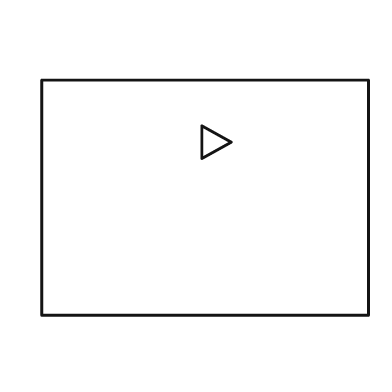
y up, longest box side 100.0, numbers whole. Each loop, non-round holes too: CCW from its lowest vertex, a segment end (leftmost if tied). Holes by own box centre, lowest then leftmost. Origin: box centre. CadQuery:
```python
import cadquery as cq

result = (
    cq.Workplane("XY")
    .moveTo(-50.0, -36.0)
    .lineTo(50.0, -36.0)
    .lineTo(50.0, 36.0)
    .lineTo(-50.0, 36.0)
    .close()
    .moveTo(-1.0, 12.0)
    .lineTo(8.0, 17.0)
    .lineTo(-1.0, 22.0)
    .close()
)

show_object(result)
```